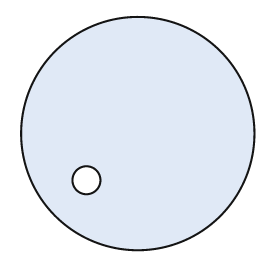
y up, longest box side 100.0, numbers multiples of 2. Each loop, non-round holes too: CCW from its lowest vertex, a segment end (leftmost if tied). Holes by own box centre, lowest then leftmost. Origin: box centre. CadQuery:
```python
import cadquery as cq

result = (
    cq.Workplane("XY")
    .moveTo(0.0, 0.0)
    .circle(50.0)
    .moveTo(-22.0, -20.0)
    .circle(6.0)
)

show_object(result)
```